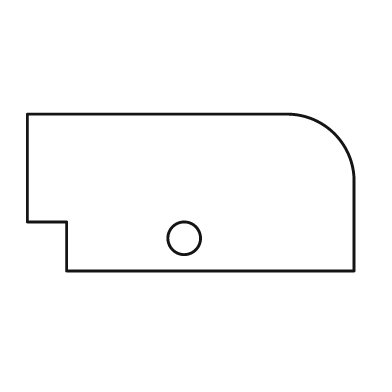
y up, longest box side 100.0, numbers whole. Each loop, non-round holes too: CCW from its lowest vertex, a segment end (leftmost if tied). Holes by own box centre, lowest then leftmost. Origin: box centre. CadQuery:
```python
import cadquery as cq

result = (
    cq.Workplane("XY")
    .moveTo(-38.0, -24.0)
    .lineTo(50.0, -24.0)
    .lineTo(50.0, 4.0)
    .threePointArc((44.0, 18.0), (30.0, 24.0))
    .lineTo(-50.0, 24.0)
    .lineTo(-50.0, -9.0)
    .lineTo(-38.0, -9.0)
    .close()
    .moveTo(-2.0, -14.0)
    .circle(5.0)
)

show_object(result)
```